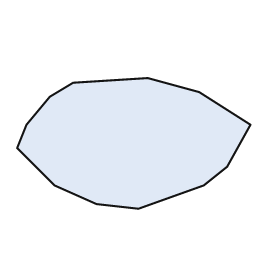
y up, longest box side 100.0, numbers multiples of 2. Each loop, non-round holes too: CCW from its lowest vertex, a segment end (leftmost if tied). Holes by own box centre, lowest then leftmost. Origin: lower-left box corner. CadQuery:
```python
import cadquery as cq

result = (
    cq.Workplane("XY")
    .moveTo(52.0, 0.0)
    .lineTo(80.0, 10.0)
    .lineTo(90.0, 18.0)
    .lineTo(100.0, 36.0)
    .lineTo(78.0, 50.0)
    .lineTo(56.0, 56.0)
    .lineTo(24.0, 54.0)
    .lineTo(14.0, 48.0)
    .lineTo(4.0, 36.0)
    .lineTo(0.0, 26.0)
    .lineTo(16.0, 10.0)
    .lineTo(34.0, 2.0)
    .close()
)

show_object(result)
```